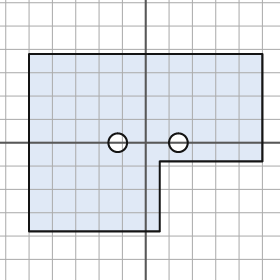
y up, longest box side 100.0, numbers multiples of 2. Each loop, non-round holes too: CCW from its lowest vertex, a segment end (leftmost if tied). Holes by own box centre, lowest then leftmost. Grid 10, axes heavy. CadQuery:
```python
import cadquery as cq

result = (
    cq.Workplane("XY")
    .moveTo(-50.0, -38.0)
    .lineTo(6.0, -38.0)
    .lineTo(6.0, -8.0)
    .lineTo(50.0, -8.0)
    .lineTo(50.0, 38.0)
    .lineTo(-50.0, 38.0)
    .close()
    .moveTo(-12.0, 0.0)
    .circle(4.0)
    .moveTo(14.0, 0.0)
    .circle(4.0)
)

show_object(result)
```